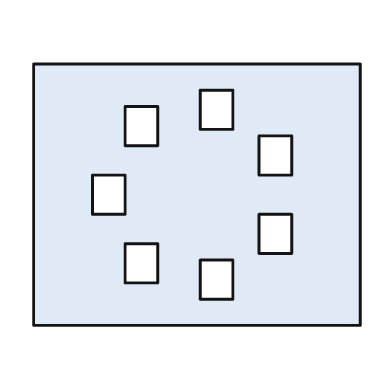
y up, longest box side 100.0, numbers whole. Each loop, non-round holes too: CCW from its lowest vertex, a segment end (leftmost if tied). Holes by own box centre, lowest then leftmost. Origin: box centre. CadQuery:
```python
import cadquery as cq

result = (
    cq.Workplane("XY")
    .moveTo(-50.0, -40.0)
    .lineTo(50.0, -40.0)
    .lineTo(50.0, 40.0)
    .lineTo(-50.0, 40.0)
    .close()
    .moveTo(1.0, -32.0)
    .lineTo(11.0, -32.0)
    .lineTo(11.0, -20.0)
    .lineTo(1.0, -20.0)
    .close()
    .moveTo(-22.0, -27.0)
    .lineTo(-12.0, -27.0)
    .lineTo(-12.0, -15.0)
    .lineTo(-22.0, -15.0)
    .close()
    .moveTo(19.0, -18.0)
    .lineTo(29.0, -18.0)
    .lineTo(29.0, -6.0)
    .lineTo(19.0, -6.0)
    .close()
    .moveTo(-32.0, -6.0)
    .lineTo(-22.0, -6.0)
    .lineTo(-22.0, 6.0)
    .lineTo(-32.0, 6.0)
    .close()
    .moveTo(19.0, 6.0)
    .lineTo(29.0, 6.0)
    .lineTo(29.0, 18.0)
    .lineTo(19.0, 18.0)
    .close()
    .moveTo(-22.0, 15.0)
    .lineTo(-12.0, 15.0)
    .lineTo(-12.0, 27.0)
    .lineTo(-22.0, 27.0)
    .close()
    .moveTo(1.0, 20.0)
    .lineTo(11.0, 20.0)
    .lineTo(11.0, 32.0)
    .lineTo(1.0, 32.0)
    .close()
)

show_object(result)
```